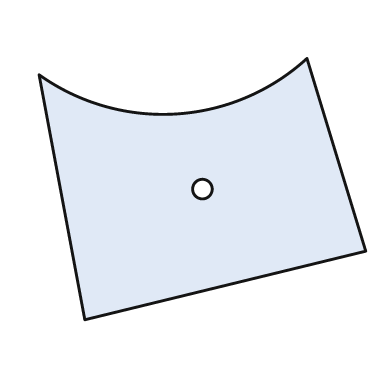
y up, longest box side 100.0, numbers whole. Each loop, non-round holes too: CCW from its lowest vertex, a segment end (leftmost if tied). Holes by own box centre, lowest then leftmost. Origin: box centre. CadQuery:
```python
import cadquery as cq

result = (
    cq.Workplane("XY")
    .moveTo(-36.0, -40.0)
    .lineTo(50.0, -19.0)
    .lineTo(32.0, 40.0)
    .threePointArc((-8.0, 23.0), (-50.0, 35.0))
    .close()
    .moveTo(0.0, 0.0)
    .circle(3.0)
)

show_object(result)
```